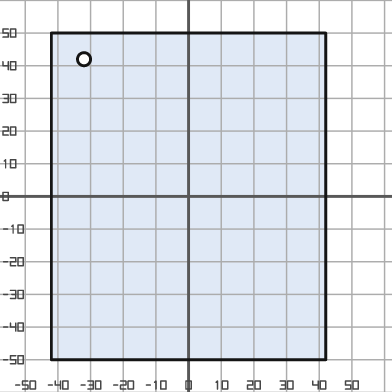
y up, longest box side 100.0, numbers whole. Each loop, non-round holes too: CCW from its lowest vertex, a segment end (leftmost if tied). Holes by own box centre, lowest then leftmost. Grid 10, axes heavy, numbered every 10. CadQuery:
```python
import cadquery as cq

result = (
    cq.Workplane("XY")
    .moveTo(-42.0, -50.0)
    .lineTo(42.0, -50.0)
    .lineTo(42.0, 50.0)
    .lineTo(-42.0, 50.0)
    .close()
    .moveTo(-32.0, 42.0)
    .circle(2.0)
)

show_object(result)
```